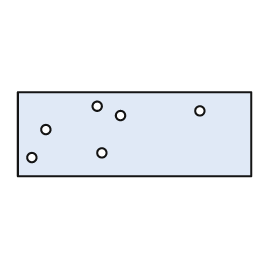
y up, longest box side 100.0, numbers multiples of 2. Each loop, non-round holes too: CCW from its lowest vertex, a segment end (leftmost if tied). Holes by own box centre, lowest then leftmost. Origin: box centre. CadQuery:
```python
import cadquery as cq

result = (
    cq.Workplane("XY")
    .moveTo(-50.0, -18.0)
    .lineTo(50.0, -18.0)
    .lineTo(50.0, 18.0)
    .lineTo(-50.0, 18.0)
    .close()
    .moveTo(-44.0, -10.0)
    .circle(2.0)
    .moveTo(-14.0, -8.0)
    .circle(2.0)
    .moveTo(-38.0, 2.0)
    .circle(2.0)
    .moveTo(-6.0, 8.0)
    .circle(2.0)
    .moveTo(28.0, 10.0)
    .circle(2.0)
    .moveTo(-16.0, 12.0)
    .circle(2.0)
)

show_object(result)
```